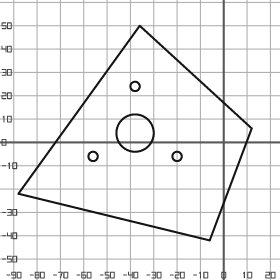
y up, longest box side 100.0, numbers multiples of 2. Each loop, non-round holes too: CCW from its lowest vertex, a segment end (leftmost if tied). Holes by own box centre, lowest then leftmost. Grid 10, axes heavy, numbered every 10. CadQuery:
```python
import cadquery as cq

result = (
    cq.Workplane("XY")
    .moveTo(-6.0, -42.0)
    .lineTo(12.0, 6.0)
    .lineTo(-36.0, 50.0)
    .lineTo(-88.0, -22.0)
    .close()
    .moveTo(-56.0, -6.0)
    .circle(2.0)
    .moveTo(-20.0, -6.0)
    .circle(2.0)
    .moveTo(-38.0, 4.0)
    .circle(8.0)
    .moveTo(-38.0, 24.0)
    .circle(2.0)
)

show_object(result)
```